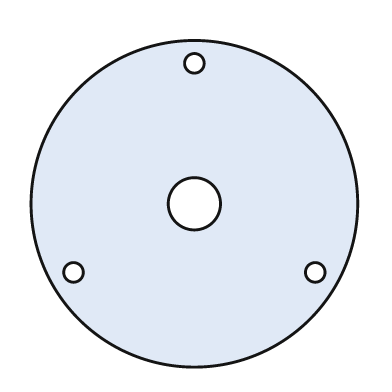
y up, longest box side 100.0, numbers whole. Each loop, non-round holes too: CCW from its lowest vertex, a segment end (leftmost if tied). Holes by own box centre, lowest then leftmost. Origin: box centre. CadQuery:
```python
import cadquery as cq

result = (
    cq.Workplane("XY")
    .moveTo(0.0, 0.0)
    .circle(50.0)
    .moveTo(-37.0, -21.0)
    .circle(3.0)
    .moveTo(37.0, -21.0)
    .circle(3.0)
    .moveTo(0.0, 0.0)
    .circle(8.0)
    .moveTo(0.0, 43.0)
    .circle(3.0)
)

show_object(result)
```